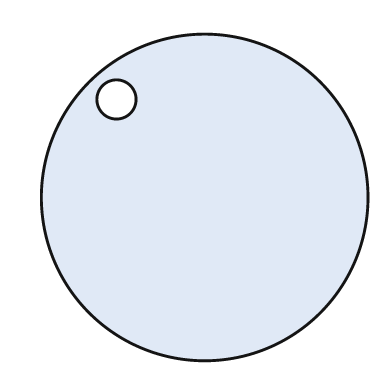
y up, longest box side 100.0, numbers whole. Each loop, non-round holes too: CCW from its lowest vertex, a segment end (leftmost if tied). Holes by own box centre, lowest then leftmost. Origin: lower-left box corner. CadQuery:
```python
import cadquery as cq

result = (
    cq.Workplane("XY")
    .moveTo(50.0, 50.0)
    .circle(50.0)
    .moveTo(23.0, 80.0)
    .circle(6.0)
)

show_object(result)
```